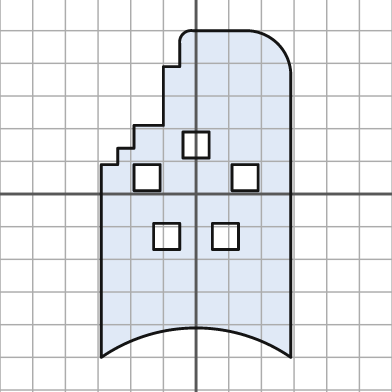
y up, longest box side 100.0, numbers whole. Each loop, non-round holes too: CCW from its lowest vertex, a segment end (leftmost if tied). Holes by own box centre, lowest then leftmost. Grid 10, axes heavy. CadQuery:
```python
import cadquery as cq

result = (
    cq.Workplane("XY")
    .moveTo(-29.0, -50.0)
    .threePointArc((0.0, -41.0), (29.0, -50.0))
    .lineTo(29.0, 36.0)
    .threePointArc((25.0, 46.0), (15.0, 50.0))
    .lineTo(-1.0, 50.0)
    .threePointArc((-4.0, 49.0), (-5.0, 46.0))
    .lineTo(-5.0, 39.0)
    .lineTo(-10.0, 39.0)
    .lineTo(-10.0, 21.0)
    .lineTo(-19.0, 21.0)
    .lineTo(-19.0, 14.0)
    .lineTo(-24.0, 14.0)
    .lineTo(-24.0, 9.0)
    .lineTo(-29.0, 9.0)
    .close()
    .moveTo(-13.0, -17.0)
    .lineTo(-5.0, -17.0)
    .lineTo(-5.0, -9.0)
    .lineTo(-13.0, -9.0)
    .close()
    .moveTo(5.0, -17.0)
    .lineTo(13.0, -17.0)
    .lineTo(13.0, -9.0)
    .lineTo(5.0, -9.0)
    .close()
    .moveTo(-19.0, 1.0)
    .lineTo(-11.0, 1.0)
    .lineTo(-11.0, 9.0)
    .lineTo(-19.0, 9.0)
    .close()
    .moveTo(11.0, 1.0)
    .lineTo(19.0, 1.0)
    .lineTo(19.0, 9.0)
    .lineTo(11.0, 9.0)
    .close()
    .moveTo(-4.0, 11.0)
    .lineTo(4.0, 11.0)
    .lineTo(4.0, 19.0)
    .lineTo(-4.0, 19.0)
    .close()
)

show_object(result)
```